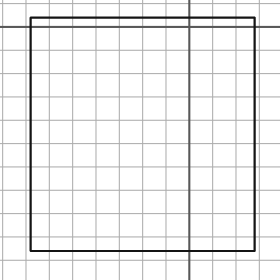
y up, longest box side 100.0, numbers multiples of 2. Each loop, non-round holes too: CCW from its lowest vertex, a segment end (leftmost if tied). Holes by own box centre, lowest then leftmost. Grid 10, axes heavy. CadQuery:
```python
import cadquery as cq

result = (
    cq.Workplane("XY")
    .moveTo(-68.0, -96.0)
    .lineTo(28.0, -96.0)
    .lineTo(28.0, 4.0)
    .lineTo(-68.0, 4.0)
    .close()
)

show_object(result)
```